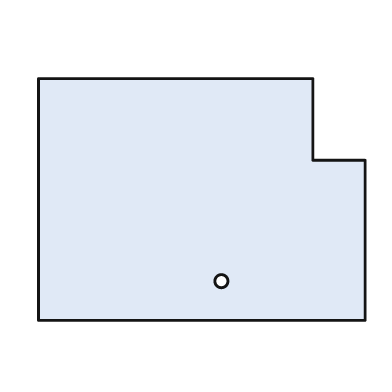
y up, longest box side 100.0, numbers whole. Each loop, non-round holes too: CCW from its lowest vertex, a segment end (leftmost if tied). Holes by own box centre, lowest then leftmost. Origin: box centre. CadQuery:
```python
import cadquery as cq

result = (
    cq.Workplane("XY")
    .moveTo(-50.0, -37.0)
    .lineTo(50.0, -37.0)
    .lineTo(50.0, 12.0)
    .lineTo(34.0, 12.0)
    .lineTo(34.0, 37.0)
    .lineTo(-50.0, 37.0)
    .close()
    .moveTo(6.0, -25.0)
    .circle(2.0)
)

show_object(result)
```